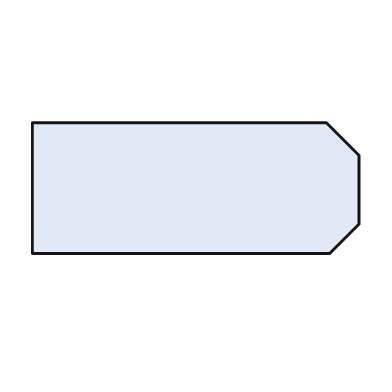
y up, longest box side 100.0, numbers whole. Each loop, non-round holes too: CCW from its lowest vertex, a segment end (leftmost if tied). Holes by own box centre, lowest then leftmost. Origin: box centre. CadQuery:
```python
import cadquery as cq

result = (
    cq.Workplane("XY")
    .moveTo(-50.0, -20.0)
    .lineTo(41.0, -20.0)
    .lineTo(50.0, -11.0)
    .lineTo(50.0, 10.0)
    .lineTo(40.0, 20.0)
    .lineTo(-50.0, 20.0)
    .close()
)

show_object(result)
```